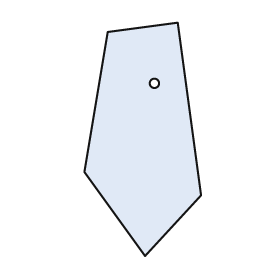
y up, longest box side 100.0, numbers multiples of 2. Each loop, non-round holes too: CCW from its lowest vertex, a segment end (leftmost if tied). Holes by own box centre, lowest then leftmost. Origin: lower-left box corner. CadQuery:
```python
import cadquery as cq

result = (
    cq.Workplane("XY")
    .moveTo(26.0, 0.0)
    .lineTo(50.0, 26.0)
    .lineTo(40.0, 100.0)
    .lineTo(10.0, 96.0)
    .lineTo(0.0, 36.0)
    .close()
    .moveTo(30.0, 74.0)
    .circle(2.0)
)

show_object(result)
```